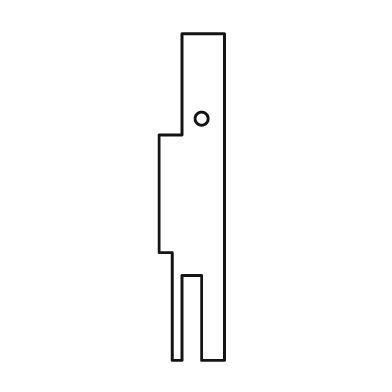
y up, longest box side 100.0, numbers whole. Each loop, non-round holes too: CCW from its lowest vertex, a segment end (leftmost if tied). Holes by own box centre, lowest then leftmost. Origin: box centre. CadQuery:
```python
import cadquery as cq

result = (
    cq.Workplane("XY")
    .moveTo(-6.0, -50.0)
    .lineTo(-3.0, -50.0)
    .lineTo(-3.0, -24.0)
    .lineTo(3.0, -24.0)
    .lineTo(3.0, -50.0)
    .lineTo(10.0, -50.0)
    .lineTo(10.0, 50.0)
    .lineTo(-3.0, 50.0)
    .lineTo(-3.0, 19.0)
    .lineTo(-10.0, 19.0)
    .lineTo(-10.0, -17.0)
    .lineTo(-6.0, -17.0)
    .close()
    .moveTo(3.0, 24.0)
    .circle(2.0)
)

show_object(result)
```